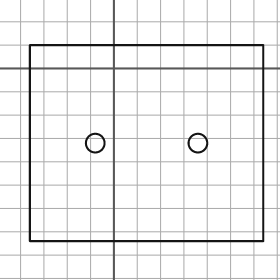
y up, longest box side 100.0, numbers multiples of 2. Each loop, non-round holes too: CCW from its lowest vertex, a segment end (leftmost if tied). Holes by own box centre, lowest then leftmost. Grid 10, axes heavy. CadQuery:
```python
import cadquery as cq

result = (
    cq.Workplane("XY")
    .moveTo(-36.0, -74.0)
    .lineTo(64.0, -74.0)
    .lineTo(64.0, 10.0)
    .lineTo(-36.0, 10.0)
    .close()
    .moveTo(-8.0, -32.0)
    .circle(4.0)
    .moveTo(36.0, -32.0)
    .circle(4.0)
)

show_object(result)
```